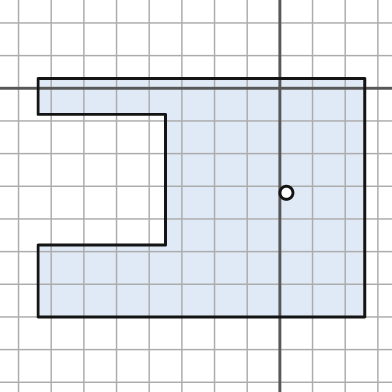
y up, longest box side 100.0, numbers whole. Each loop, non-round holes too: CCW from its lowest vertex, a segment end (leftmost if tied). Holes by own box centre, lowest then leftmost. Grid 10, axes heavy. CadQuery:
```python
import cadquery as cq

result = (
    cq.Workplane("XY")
    .moveTo(-74.0, -70.0)
    .lineTo(26.0, -70.0)
    .lineTo(26.0, 3.0)
    .lineTo(-74.0, 3.0)
    .lineTo(-74.0, -8.0)
    .lineTo(-35.0, -8.0)
    .lineTo(-35.0, -48.0)
    .lineTo(-74.0, -48.0)
    .close()
    .moveTo(2.0, -32.0)
    .circle(2.0)
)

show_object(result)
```